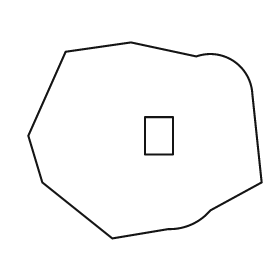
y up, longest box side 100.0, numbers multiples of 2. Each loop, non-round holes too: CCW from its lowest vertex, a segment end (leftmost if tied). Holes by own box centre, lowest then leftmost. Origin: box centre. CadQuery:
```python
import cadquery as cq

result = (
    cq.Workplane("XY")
    .moveTo(-14.0, -42.0)
    .lineTo(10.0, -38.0)
    .threePointArc((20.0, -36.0), (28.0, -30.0))
    .lineTo(50.0, -18.0)
    .lineTo(46.0, 20.0)
    .threePointArc((38.0, 34.0), (22.0, 36.0))
    .lineTo(-6.0, 42.0)
    .lineTo(-34.0, 38.0)
    .lineTo(-50.0, 2.0)
    .lineTo(-44.0, -18.0)
    .close()
    .moveTo(0.0, -6.0)
    .lineTo(12.0, -6.0)
    .lineTo(12.0, 10.0)
    .lineTo(0.0, 10.0)
    .close()
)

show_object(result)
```